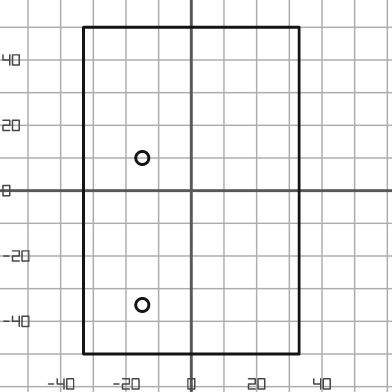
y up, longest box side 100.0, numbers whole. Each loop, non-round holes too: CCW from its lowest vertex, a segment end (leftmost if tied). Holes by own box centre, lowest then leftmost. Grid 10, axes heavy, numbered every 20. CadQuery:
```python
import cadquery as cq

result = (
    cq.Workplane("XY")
    .moveTo(-33.0, -50.0)
    .lineTo(33.0, -50.0)
    .lineTo(33.0, 50.0)
    .lineTo(-33.0, 50.0)
    .close()
    .moveTo(-15.0, -35.0)
    .circle(2.0)
    .moveTo(-15.0, 10.0)
    .circle(2.0)
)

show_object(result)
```